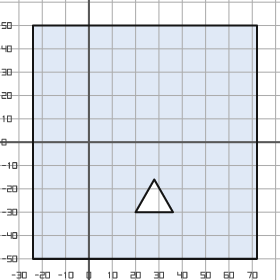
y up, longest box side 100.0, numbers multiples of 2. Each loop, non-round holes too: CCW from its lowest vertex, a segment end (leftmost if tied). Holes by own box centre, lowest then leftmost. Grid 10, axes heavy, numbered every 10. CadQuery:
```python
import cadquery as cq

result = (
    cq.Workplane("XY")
    .moveTo(-24.0, -50.0)
    .lineTo(72.0, -50.0)
    .lineTo(72.0, 50.0)
    .lineTo(-24.0, 50.0)
    .close()
    .moveTo(20.0, -30.0)
    .lineTo(36.0, -30.0)
    .lineTo(28.0, -16.0)
    .close()
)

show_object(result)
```